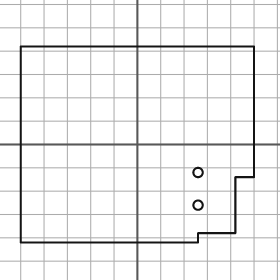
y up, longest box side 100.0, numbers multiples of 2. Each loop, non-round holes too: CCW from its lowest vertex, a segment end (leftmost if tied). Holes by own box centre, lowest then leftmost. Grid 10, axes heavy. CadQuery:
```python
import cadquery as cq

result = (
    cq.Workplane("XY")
    .moveTo(-50.0, -42.0)
    .lineTo(26.0, -42.0)
    .lineTo(26.0, -38.0)
    .lineTo(42.0, -38.0)
    .lineTo(42.0, -14.0)
    .lineTo(50.0, -14.0)
    .lineTo(50.0, 42.0)
    .lineTo(-50.0, 42.0)
    .close()
    .moveTo(26.0, -26.0)
    .circle(2.0)
    .moveTo(26.0, -12.0)
    .circle(2.0)
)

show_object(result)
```